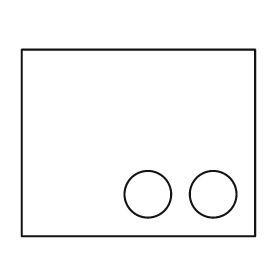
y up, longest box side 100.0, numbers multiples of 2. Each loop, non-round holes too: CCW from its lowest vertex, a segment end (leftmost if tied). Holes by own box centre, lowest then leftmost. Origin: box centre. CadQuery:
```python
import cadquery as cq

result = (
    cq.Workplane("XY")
    .moveTo(-50.0, -40.0)
    .lineTo(50.0, -40.0)
    .lineTo(50.0, 40.0)
    .lineTo(-50.0, 40.0)
    .close()
    .moveTo(4.0, -22.0)
    .circle(10.0)
    .moveTo(32.0, -22.0)
    .circle(10.0)
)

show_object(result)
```